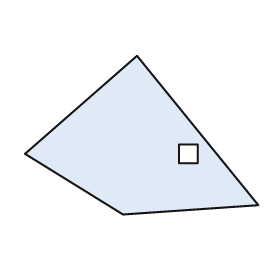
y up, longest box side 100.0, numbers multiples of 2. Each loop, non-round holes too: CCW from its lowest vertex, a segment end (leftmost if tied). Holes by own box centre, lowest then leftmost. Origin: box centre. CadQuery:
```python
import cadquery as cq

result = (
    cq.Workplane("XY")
    .moveTo(-8.0, -34.0)
    .lineTo(50.0, -30.0)
    .lineTo(-2.0, 34.0)
    .lineTo(-50.0, -8.0)
    .close()
    .moveTo(16.0, -12.0)
    .lineTo(24.0, -12.0)
    .lineTo(24.0, -4.0)
    .lineTo(16.0, -4.0)
    .close()
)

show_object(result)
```